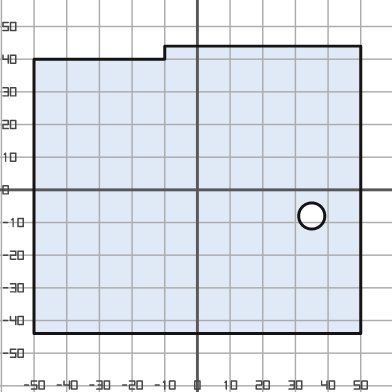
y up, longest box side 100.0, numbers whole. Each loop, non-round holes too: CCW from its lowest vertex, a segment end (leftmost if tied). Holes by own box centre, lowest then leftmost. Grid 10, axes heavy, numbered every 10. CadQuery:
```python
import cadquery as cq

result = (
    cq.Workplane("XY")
    .moveTo(-50.0, -44.0)
    .lineTo(50.0, -44.0)
    .lineTo(50.0, 44.0)
    .lineTo(-10.0, 44.0)
    .lineTo(-10.0, 40.0)
    .lineTo(-50.0, 40.0)
    .close()
    .moveTo(35.0, -8.0)
    .circle(4.0)
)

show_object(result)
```